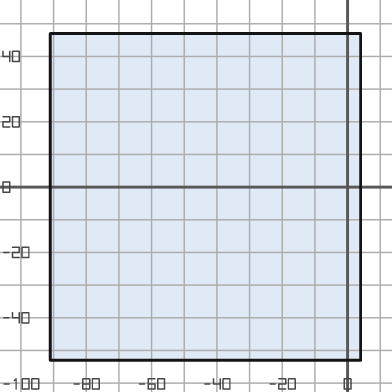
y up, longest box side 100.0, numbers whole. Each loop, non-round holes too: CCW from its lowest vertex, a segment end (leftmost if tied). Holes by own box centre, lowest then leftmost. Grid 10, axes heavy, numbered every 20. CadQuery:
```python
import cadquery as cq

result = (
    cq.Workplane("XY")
    .moveTo(-91.0, -53.0)
    .lineTo(4.0, -53.0)
    .lineTo(4.0, 47.0)
    .lineTo(-91.0, 47.0)
    .close()
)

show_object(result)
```